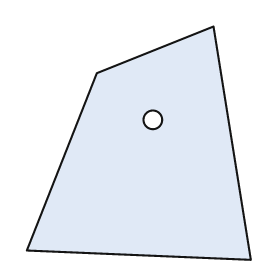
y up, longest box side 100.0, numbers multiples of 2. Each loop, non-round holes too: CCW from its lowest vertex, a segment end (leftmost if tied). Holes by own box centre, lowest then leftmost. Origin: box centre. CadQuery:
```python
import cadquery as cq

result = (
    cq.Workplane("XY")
    .moveTo(48.0, -50.0)
    .lineTo(32.0, 50.0)
    .lineTo(-18.0, 30.0)
    .lineTo(-48.0, -46.0)
    .close()
    .moveTo(6.0, 10.0)
    .circle(4.0)
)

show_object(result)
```